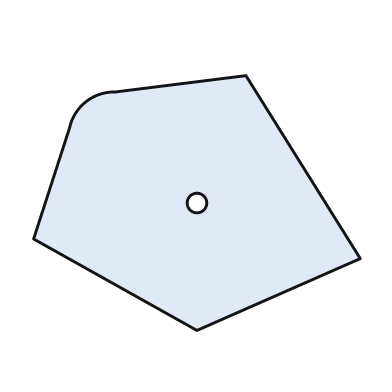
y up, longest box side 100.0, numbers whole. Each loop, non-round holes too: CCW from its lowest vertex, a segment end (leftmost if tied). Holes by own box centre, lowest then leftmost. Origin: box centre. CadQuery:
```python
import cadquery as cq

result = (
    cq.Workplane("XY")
    .moveTo(0.0, -39.0)
    .lineTo(50.0, -17.0)
    .lineTo(15.0, 39.0)
    .lineTo(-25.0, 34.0)
    .threePointArc((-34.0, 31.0), (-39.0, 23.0))
    .lineTo(-50.0, -11.0)
    .close()
    .moveTo(0.0, 0.0)
    .circle(3.0)
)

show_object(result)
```